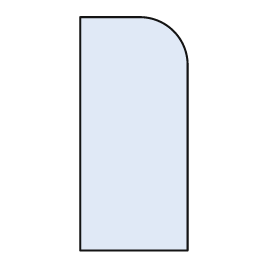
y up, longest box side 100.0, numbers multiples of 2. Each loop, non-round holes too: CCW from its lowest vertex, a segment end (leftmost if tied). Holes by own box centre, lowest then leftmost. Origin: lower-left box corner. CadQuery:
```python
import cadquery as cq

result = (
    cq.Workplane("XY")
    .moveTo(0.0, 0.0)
    .lineTo(46.0, 0.0)
    .lineTo(46.0, 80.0)
    .threePointArc((40.0, 94.0), (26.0, 100.0))
    .lineTo(0.0, 100.0)
    .close()
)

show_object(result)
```